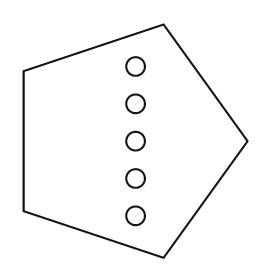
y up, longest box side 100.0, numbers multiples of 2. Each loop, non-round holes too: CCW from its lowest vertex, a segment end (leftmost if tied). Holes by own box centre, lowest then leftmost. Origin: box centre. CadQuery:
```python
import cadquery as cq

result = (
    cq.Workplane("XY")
    .moveTo(12.0, -50.0)
    .lineTo(48.0, 0.0)
    .lineTo(12.0, 50.0)
    .lineTo(-48.0, 30.0)
    .lineTo(-48.0, -30.0)
    .close()
    .moveTo(0.0, -32.0)
    .circle(4.0)
    .moveTo(0.0, -16.0)
    .circle(4.0)
    .moveTo(0.0, 0.0)
    .circle(4.0)
    .moveTo(0.0, 16.0)
    .circle(4.0)
    .moveTo(0.0, 32.0)
    .circle(4.0)
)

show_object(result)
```